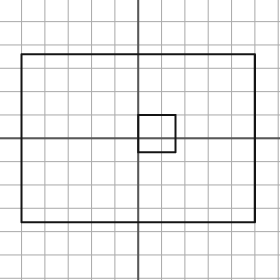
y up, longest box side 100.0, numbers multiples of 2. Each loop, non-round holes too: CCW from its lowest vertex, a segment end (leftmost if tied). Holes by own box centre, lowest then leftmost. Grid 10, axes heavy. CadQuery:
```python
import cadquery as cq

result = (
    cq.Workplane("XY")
    .moveTo(-50.0, -36.0)
    .lineTo(50.0, -36.0)
    .lineTo(50.0, 36.0)
    .lineTo(-50.0, 36.0)
    .close()
    .moveTo(0.0, -6.0)
    .lineTo(16.0, -6.0)
    .lineTo(16.0, 10.0)
    .lineTo(0.0, 10.0)
    .close()
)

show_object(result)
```